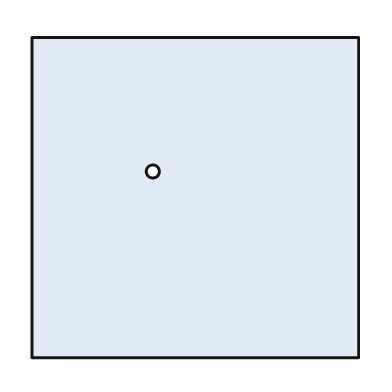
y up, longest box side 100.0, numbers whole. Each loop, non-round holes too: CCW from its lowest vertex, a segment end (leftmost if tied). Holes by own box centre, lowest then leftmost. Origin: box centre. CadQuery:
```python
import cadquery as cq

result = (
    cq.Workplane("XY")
    .moveTo(-50.0, -49.0)
    .lineTo(50.0, -49.0)
    .lineTo(50.0, 49.0)
    .lineTo(-50.0, 49.0)
    .close()
    .moveTo(-13.0, 8.0)
    .circle(2.0)
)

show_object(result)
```